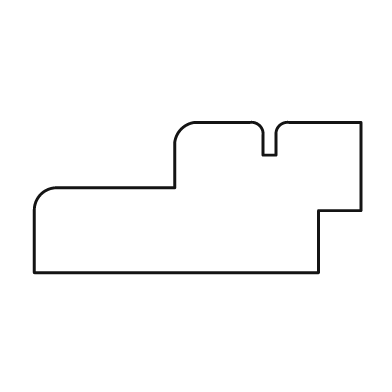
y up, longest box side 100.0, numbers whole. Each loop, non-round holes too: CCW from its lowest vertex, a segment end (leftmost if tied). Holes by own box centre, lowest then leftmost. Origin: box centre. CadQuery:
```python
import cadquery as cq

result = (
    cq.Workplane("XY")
    .moveTo(-50.0, -23.0)
    .lineTo(37.0, -23.0)
    .lineTo(37.0, -4.0)
    .lineTo(50.0, -4.0)
    .lineTo(50.0, 23.0)
    .lineTo(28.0, 23.0)
    .threePointArc((25.0, 22.0), (24.0, 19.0))
    .lineTo(24.0, 13.0)
    .lineTo(20.0, 13.0)
    .lineTo(20.0, 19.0)
    .threePointArc((19.0, 22.0), (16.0, 23.0))
    .lineTo(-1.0, 23.0)
    .threePointArc((-5.0, 21.0), (-7.0, 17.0))
    .lineTo(-7.0, 3.0)
    .lineTo(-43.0, 3.0)
    .threePointArc((-48.0, 1.0), (-50.0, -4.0))
    .close()
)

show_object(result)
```